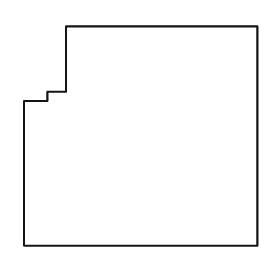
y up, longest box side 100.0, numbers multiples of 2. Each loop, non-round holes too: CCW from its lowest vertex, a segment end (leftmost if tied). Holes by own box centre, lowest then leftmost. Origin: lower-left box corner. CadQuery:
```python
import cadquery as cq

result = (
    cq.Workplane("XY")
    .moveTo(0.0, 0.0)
    .lineTo(100.0, 0.0)
    .lineTo(100.0, 94.0)
    .lineTo(18.0, 94.0)
    .lineTo(18.0, 66.0)
    .lineTo(10.0, 66.0)
    .lineTo(10.0, 62.0)
    .lineTo(0.0, 62.0)
    .close()
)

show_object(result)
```